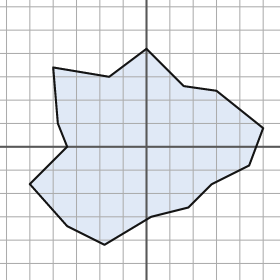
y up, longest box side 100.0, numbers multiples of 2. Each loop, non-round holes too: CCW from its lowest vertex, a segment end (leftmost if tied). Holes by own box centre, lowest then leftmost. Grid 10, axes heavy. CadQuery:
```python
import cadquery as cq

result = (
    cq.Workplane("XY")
    .moveTo(-18.0, -42.0)
    .lineTo(2.0, -30.0)
    .lineTo(18.0, -26.0)
    .lineTo(28.0, -16.0)
    .lineTo(44.0, -8.0)
    .lineTo(50.0, 8.0)
    .lineTo(30.0, 24.0)
    .lineTo(16.0, 26.0)
    .lineTo(0.0, 42.0)
    .lineTo(-16.0, 30.0)
    .lineTo(-40.0, 34.0)
    .lineTo(-38.0, 10.0)
    .lineTo(-34.0, 0.0)
    .lineTo(-50.0, -16.0)
    .lineTo(-34.0, -34.0)
    .close()
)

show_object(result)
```